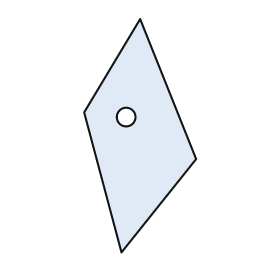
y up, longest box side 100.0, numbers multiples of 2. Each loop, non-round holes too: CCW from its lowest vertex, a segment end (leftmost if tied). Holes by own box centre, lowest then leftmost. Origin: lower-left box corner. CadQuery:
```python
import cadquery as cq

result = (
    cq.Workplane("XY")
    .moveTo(16.0, 0.0)
    .lineTo(48.0, 40.0)
    .lineTo(24.0, 100.0)
    .lineTo(0.0, 60.0)
    .close()
    .moveTo(18.0, 58.0)
    .circle(4.0)
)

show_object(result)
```